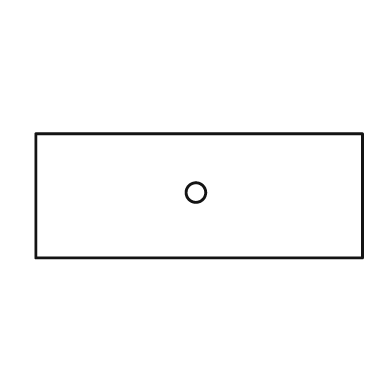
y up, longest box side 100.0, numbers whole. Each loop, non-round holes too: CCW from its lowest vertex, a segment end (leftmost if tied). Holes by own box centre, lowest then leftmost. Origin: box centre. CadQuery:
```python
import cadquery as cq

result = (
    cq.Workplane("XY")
    .moveTo(-50.0, -19.0)
    .lineTo(50.0, -19.0)
    .lineTo(50.0, 19.0)
    .lineTo(-50.0, 19.0)
    .close()
    .moveTo(-1.0, 1.0)
    .circle(3.0)
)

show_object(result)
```